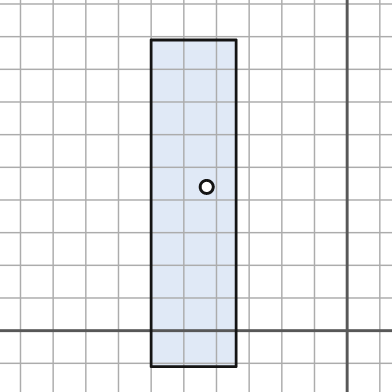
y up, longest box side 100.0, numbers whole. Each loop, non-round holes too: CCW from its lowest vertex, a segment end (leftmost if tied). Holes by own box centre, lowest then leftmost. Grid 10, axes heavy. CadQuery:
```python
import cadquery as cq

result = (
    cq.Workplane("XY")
    .moveTo(-60.0, -11.0)
    .lineTo(-34.0, -11.0)
    .lineTo(-34.0, 89.0)
    .lineTo(-60.0, 89.0)
    .close()
    .moveTo(-43.0, 44.0)
    .circle(2.0)
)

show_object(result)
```